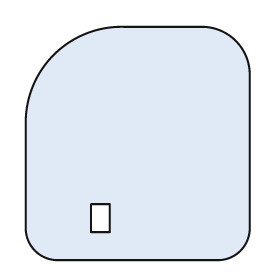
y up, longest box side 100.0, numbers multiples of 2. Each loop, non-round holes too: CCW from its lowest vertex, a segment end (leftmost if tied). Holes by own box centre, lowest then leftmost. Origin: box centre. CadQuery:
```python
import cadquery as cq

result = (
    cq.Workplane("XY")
    .moveTo(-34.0, -50.0)
    .lineTo(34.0, -50.0)
    .threePointArc((44.0, -46.0), (48.0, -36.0))
    .lineTo(48.0, 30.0)
    .threePointArc((42.0, 44.0), (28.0, 50.0))
    .lineTo(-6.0, 50.0)
    .threePointArc((-36.0, 38.0), (-48.0, 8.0))
    .lineTo(-48.0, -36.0)
    .threePointArc((-44.0, -46.0), (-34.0, -50.0))
    .close()
    .moveTo(-20.0, -38.0)
    .lineTo(-12.0, -38.0)
    .lineTo(-12.0, -26.0)
    .lineTo(-20.0, -26.0)
    .close()
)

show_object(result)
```